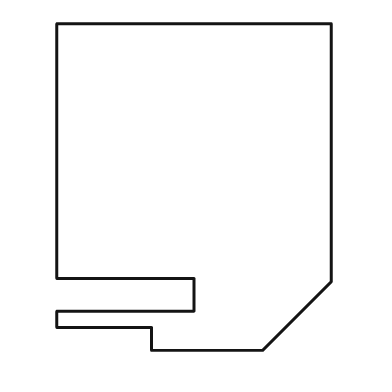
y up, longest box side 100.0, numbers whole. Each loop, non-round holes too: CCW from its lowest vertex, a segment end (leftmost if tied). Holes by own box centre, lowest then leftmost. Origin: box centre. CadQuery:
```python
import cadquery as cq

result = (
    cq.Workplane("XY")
    .moveTo(-13.0, -50.0)
    .lineTo(21.0, -50.0)
    .lineTo(42.0, -29.0)
    .lineTo(42.0, 50.0)
    .lineTo(-42.0, 50.0)
    .lineTo(-42.0, -28.0)
    .lineTo(0.0, -28.0)
    .lineTo(0.0, -38.0)
    .lineTo(-42.0, -38.0)
    .lineTo(-42.0, -43.0)
    .lineTo(-13.0, -43.0)
    .close()
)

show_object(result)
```